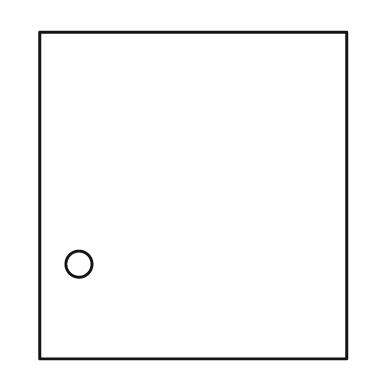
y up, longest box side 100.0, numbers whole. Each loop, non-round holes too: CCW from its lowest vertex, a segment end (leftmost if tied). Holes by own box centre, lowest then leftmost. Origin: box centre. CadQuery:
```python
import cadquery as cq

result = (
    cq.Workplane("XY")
    .moveTo(-47.0, -50.0)
    .lineTo(47.0, -50.0)
    .lineTo(47.0, 50.0)
    .lineTo(-47.0, 50.0)
    .close()
    .moveTo(-35.0, -21.0)
    .circle(4.0)
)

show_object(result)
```